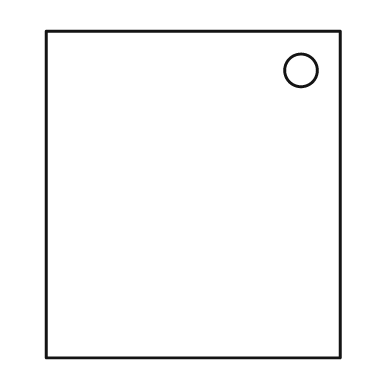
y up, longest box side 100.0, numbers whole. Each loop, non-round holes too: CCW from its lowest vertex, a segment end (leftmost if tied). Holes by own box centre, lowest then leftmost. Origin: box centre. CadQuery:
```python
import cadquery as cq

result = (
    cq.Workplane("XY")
    .moveTo(-45.0, -50.0)
    .lineTo(45.0, -50.0)
    .lineTo(45.0, 50.0)
    .lineTo(-45.0, 50.0)
    .close()
    .moveTo(33.0, 38.0)
    .circle(5.0)
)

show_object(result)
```